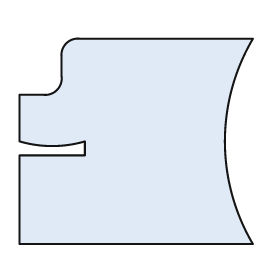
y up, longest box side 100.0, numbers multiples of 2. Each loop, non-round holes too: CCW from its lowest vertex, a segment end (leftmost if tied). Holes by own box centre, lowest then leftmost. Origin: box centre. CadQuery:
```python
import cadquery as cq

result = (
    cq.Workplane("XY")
    .moveTo(-50.0, -44.0)
    .lineTo(50.0, -44.0)
    .threePointArc((38.0, 0.0), (50.0, 44.0))
    .lineTo(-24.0, 44.0)
    .threePointArc((-30.0, 42.0), (-32.0, 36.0))
    .lineTo(-32.0, 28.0)
    .threePointArc((-34.0, 22.0), (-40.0, 20.0))
    .lineTo(-50.0, 20.0)
    .lineTo(-50.0, 0.0)
    .threePointArc((-36.0, -2.0), (-22.0, 0.0))
    .lineTo(-22.0, -6.0)
    .lineTo(-50.0, -6.0)
    .close()
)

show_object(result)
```